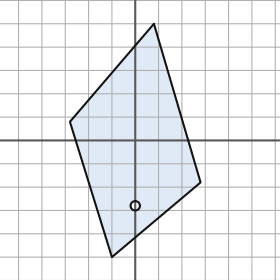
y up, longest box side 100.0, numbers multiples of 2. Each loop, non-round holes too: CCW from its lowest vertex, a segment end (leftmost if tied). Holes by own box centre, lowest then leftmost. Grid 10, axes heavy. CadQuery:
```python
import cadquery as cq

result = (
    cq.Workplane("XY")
    .moveTo(-10.0, -50.0)
    .lineTo(28.0, -18.0)
    .lineTo(8.0, 50.0)
    .lineTo(-28.0, 8.0)
    .close()
    .moveTo(0.0, -28.0)
    .circle(2.0)
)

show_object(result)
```